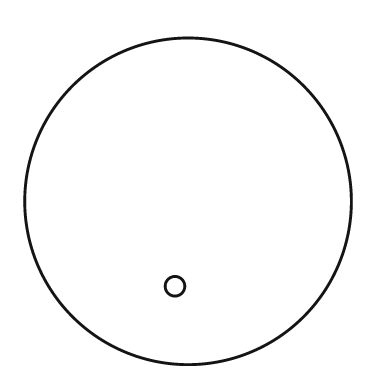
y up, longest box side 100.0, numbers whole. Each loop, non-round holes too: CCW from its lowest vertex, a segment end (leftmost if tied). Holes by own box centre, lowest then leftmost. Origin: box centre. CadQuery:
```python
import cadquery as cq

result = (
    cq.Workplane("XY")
    .moveTo(0.0, 0.0)
    .circle(50.0)
    .moveTo(-4.0, -26.0)
    .circle(3.0)
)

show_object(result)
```